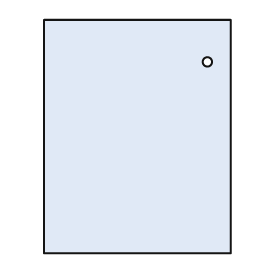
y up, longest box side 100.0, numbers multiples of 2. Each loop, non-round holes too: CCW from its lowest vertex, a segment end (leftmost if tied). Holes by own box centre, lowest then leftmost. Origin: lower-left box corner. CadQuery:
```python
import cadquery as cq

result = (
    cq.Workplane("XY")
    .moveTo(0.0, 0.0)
    .lineTo(80.0, 0.0)
    .lineTo(80.0, 100.0)
    .lineTo(0.0, 100.0)
    .close()
    .moveTo(70.0, 82.0)
    .circle(2.0)
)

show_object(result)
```